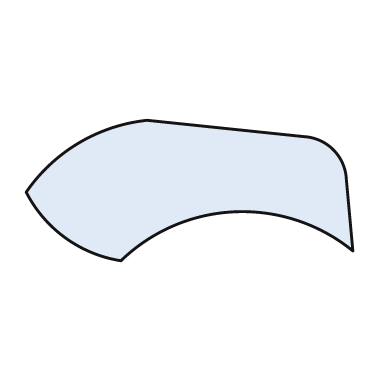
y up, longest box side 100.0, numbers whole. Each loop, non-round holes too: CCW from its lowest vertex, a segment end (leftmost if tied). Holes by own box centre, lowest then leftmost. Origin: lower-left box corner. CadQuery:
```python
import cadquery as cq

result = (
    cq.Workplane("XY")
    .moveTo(29.0, 0.0)
    .threePointArc((64.0, 15.0), (100.0, 3.0))
    .lineTo(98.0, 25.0)
    .threePointArc((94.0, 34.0), (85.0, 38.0))
    .lineTo(37.0, 43.0)
    .threePointArc((16.0, 36.0), (0.0, 21.0))
    .threePointArc((12.0, 7.0), (29.0, 0.0))
    .close()
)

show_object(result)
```